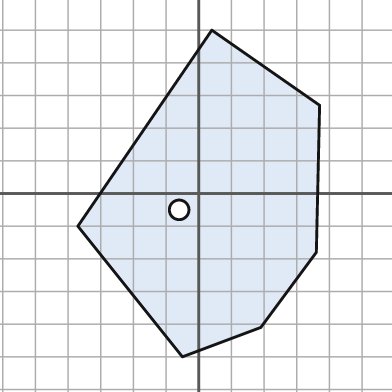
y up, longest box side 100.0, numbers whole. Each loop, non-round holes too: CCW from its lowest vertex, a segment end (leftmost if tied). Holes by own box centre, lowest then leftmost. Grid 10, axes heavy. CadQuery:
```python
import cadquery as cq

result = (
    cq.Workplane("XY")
    .moveTo(-5.0, -50.0)
    .lineTo(19.0, -41.0)
    .lineTo(36.0, -18.0)
    .lineTo(37.0, 27.0)
    .lineTo(4.0, 50.0)
    .lineTo(-37.0, -10.0)
    .close()
    .moveTo(-6.0, -5.0)
    .circle(3.0)
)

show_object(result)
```